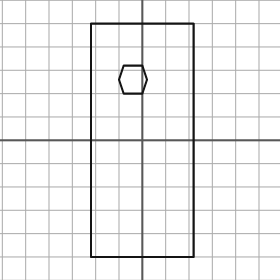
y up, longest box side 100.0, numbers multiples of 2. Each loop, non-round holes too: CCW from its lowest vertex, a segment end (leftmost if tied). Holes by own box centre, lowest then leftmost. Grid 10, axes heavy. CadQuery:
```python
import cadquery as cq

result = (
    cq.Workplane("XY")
    .moveTo(-22.0, -50.0)
    .lineTo(22.0, -50.0)
    .lineTo(22.0, 50.0)
    .lineTo(-22.0, 50.0)
    .close()
    .moveTo(-8.0, 20.0)
    .lineTo(0.0, 20.0)
    .lineTo(2.0, 26.0)
    .lineTo(0.0, 32.0)
    .lineTo(-8.0, 32.0)
    .lineTo(-10.0, 26.0)
    .close()
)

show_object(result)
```